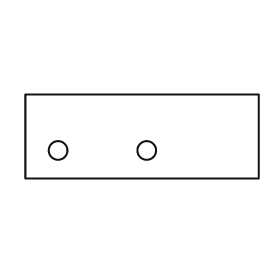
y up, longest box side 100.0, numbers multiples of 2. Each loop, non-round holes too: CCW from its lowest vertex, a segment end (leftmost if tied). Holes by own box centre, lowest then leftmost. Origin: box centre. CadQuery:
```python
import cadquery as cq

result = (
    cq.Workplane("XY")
    .moveTo(-50.0, -18.0)
    .lineTo(50.0, -18.0)
    .lineTo(50.0, 18.0)
    .lineTo(-50.0, 18.0)
    .close()
    .moveTo(-36.0, -6.0)
    .circle(4.0)
    .moveTo(2.0, -6.0)
    .circle(4.0)
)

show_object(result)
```